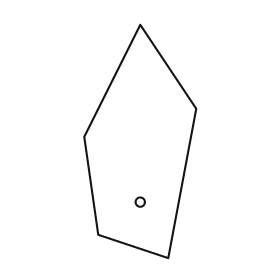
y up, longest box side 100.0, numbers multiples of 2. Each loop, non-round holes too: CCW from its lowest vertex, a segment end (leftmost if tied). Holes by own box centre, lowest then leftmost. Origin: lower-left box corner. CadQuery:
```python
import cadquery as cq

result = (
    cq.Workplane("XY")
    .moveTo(36.0, 0.0)
    .lineTo(48.0, 64.0)
    .lineTo(24.0, 100.0)
    .lineTo(0.0, 52.0)
    .lineTo(6.0, 10.0)
    .close()
    .moveTo(24.0, 24.0)
    .circle(2.0)
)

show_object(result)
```